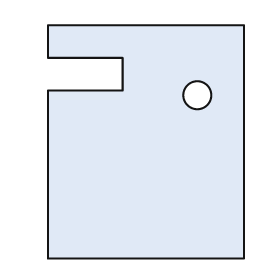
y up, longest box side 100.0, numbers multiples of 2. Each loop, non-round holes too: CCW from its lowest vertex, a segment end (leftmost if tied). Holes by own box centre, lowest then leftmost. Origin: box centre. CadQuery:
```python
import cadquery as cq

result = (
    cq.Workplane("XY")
    .moveTo(-42.0, -50.0)
    .lineTo(42.0, -50.0)
    .lineTo(42.0, 50.0)
    .lineTo(-42.0, 50.0)
    .lineTo(-42.0, 36.0)
    .lineTo(-10.0, 36.0)
    .lineTo(-10.0, 22.0)
    .lineTo(-42.0, 22.0)
    .close()
    .moveTo(22.0, 20.0)
    .circle(6.0)
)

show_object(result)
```